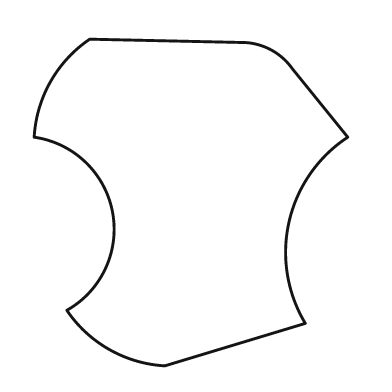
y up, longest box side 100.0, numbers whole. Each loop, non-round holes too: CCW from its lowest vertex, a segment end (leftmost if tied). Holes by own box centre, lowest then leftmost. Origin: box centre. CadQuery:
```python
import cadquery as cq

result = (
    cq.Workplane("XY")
    .moveTo(-8.0, -50.0)
    .lineTo(35.0, -37.0)
    .threePointArc((30.0, -6.0), (48.0, 20.0))
    .lineTo(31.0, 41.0)
    .threePointArc((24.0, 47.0), (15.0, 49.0))
    .lineTo(-31.0, 50.0)
    .threePointArc((-43.0, 37.0), (-48.0, 20.0))
    .threePointArc((-24.0, -3.0), (-38.0, -33.0))
    .threePointArc((-25.0, -45.0), (-8.0, -50.0))
    .close()
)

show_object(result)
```